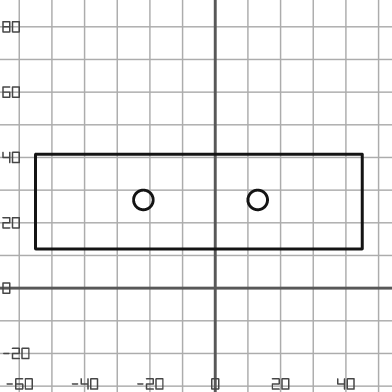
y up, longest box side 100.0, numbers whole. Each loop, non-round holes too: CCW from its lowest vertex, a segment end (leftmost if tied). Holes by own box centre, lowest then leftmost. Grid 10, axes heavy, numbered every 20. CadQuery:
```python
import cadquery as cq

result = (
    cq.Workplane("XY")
    .moveTo(-55.0, 12.0)
    .lineTo(45.0, 12.0)
    .lineTo(45.0, 41.0)
    .lineTo(-55.0, 41.0)
    .close()
    .moveTo(-22.0, 27.0)
    .circle(3.0)
    .moveTo(13.0, 27.0)
    .circle(3.0)
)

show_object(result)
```